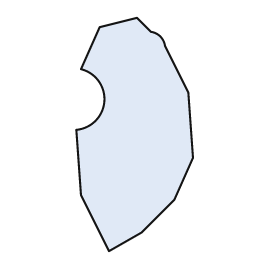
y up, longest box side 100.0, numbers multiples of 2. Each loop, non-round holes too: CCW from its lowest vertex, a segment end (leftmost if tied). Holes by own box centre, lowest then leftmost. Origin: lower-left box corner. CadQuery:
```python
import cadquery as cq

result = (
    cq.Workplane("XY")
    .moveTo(14.0, 0.0)
    .lineTo(28.0, 8.0)
    .lineTo(42.0, 22.0)
    .lineTo(50.0, 40.0)
    .lineTo(48.0, 68.0)
    .lineTo(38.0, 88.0)
    .threePointArc((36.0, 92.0), (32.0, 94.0))
    .lineTo(26.0, 100.0)
    .lineTo(10.0, 96.0)
    .lineTo(2.0, 78.0)
    .threePointArc((12.0, 64.0), (0.0, 52.0))
    .lineTo(2.0, 24.0)
    .close()
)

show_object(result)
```